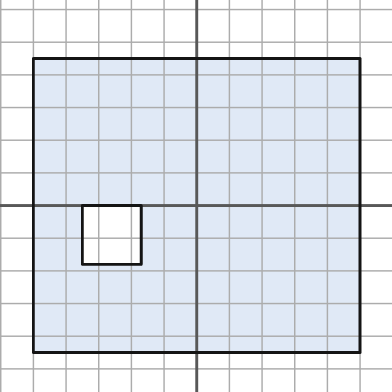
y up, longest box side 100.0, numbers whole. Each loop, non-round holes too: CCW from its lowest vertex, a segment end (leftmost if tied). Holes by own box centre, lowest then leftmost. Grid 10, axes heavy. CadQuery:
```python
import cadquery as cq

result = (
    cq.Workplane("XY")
    .moveTo(-50.0, -45.0)
    .lineTo(50.0, -45.0)
    .lineTo(50.0, 45.0)
    .lineTo(-50.0, 45.0)
    .close()
    .moveTo(-35.0, -18.0)
    .lineTo(-17.0, -18.0)
    .lineTo(-17.0, 0.0)
    .lineTo(-35.0, 0.0)
    .close()
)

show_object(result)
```